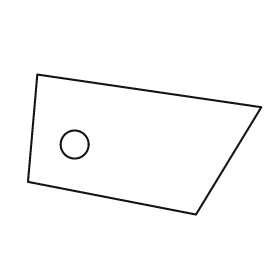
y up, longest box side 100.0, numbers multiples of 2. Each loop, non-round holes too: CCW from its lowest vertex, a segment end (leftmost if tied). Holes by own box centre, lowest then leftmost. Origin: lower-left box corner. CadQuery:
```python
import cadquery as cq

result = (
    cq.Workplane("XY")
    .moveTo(72.0, 0.0)
    .lineTo(100.0, 46.0)
    .lineTo(4.0, 60.0)
    .lineTo(0.0, 14.0)
    .close()
    .moveTo(20.0, 30.0)
    .circle(6.0)
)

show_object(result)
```